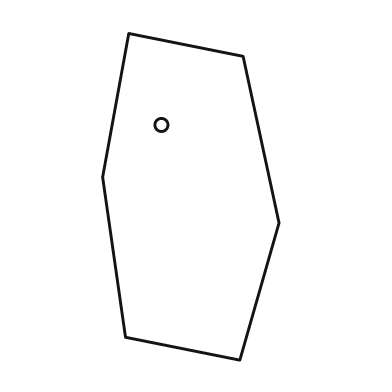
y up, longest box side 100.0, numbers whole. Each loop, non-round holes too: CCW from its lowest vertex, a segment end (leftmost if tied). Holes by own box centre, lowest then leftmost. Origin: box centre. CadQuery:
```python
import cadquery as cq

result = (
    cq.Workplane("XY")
    .moveTo(15.0, -50.0)
    .lineTo(27.0, -8.0)
    .lineTo(16.0, 43.0)
    .lineTo(-19.0, 50.0)
    .lineTo(-27.0, 6.0)
    .lineTo(-20.0, -43.0)
    .close()
    .moveTo(-9.0, 22.0)
    .circle(2.0)
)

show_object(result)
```